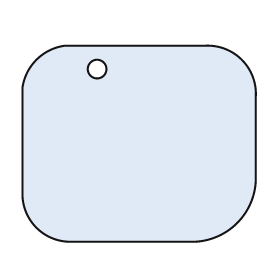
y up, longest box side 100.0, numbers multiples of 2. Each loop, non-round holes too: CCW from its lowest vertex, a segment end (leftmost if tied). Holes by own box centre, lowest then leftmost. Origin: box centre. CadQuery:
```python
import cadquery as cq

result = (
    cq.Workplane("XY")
    .moveTo(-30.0, -42.0)
    .lineTo(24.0, -42.0)
    .threePointArc((42.0, -34.0), (50.0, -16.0))
    .lineTo(50.0, 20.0)
    .threePointArc((44.0, 36.0), (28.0, 42.0))
    .lineTo(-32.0, 42.0)
    .threePointArc((-44.0, 36.0), (-50.0, 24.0))
    .lineTo(-50.0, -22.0)
    .threePointArc((-44.0, -36.0), (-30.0, -42.0))
    .close()
    .moveTo(-18.0, 32.0)
    .circle(4.0)
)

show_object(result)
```